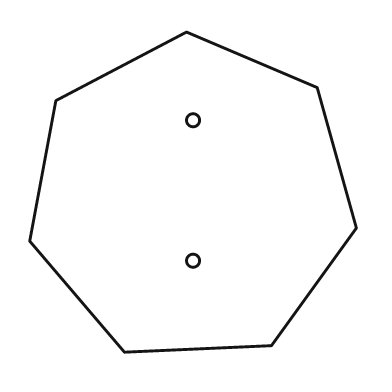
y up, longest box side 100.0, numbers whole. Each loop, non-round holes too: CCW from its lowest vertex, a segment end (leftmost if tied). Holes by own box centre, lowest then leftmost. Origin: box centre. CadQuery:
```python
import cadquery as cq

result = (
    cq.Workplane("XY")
    .moveTo(-21.0, -49.0)
    .lineTo(24.0, -47.0)
    .lineTo(50.0, -11.0)
    .lineTo(38.0, 32.0)
    .lineTo(-2.0, 49.0)
    .lineTo(-42.0, 28.0)
    .lineTo(-50.0, -15.0)
    .close()
    .moveTo(0.0, -21.0)
    .circle(2.0)
    .moveTo(0.0, 22.0)
    .circle(2.0)
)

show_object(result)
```